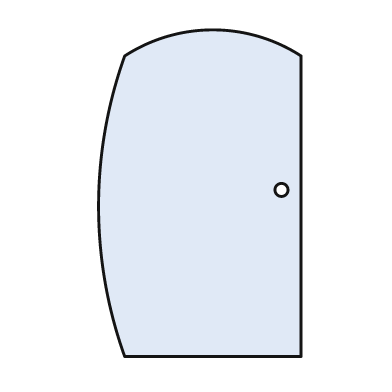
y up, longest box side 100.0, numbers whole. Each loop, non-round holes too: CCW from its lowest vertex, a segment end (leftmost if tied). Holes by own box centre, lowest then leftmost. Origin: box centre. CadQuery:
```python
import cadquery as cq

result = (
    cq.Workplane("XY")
    .moveTo(-23.0, -50.0)
    .lineTo(31.0, -50.0)
    .lineTo(31.0, 42.0)
    .threePointArc((4.0, 50.0), (-23.0, 42.0))
    .threePointArc((-31.0, -4.0), (-23.0, -50.0))
    .close()
    .moveTo(25.0, 1.0)
    .circle(2.0)
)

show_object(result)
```